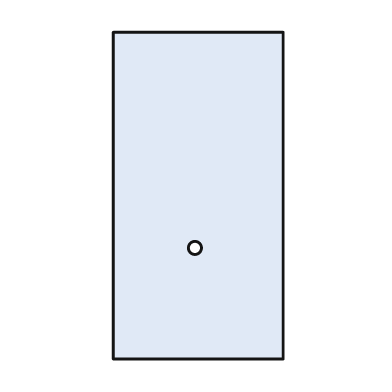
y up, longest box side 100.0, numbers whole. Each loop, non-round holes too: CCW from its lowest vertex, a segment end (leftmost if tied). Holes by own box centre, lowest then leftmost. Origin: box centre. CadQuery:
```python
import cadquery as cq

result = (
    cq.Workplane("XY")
    .moveTo(-26.0, -50.0)
    .lineTo(26.0, -50.0)
    .lineTo(26.0, 50.0)
    .lineTo(-26.0, 50.0)
    .close()
    .moveTo(-1.0, -16.0)
    .circle(2.0)
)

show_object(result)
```